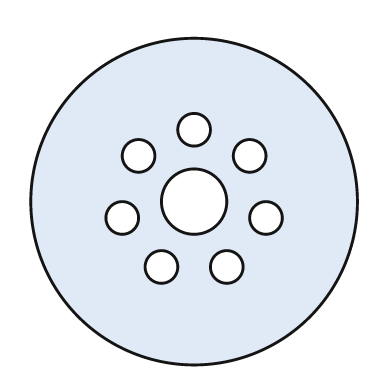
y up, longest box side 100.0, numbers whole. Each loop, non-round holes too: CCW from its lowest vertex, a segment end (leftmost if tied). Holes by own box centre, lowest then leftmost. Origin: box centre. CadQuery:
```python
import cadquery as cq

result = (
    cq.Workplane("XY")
    .moveTo(0.0, 0.0)
    .circle(50.0)
    .moveTo(-10.0, -20.0)
    .circle(5.0)
    .moveTo(10.0, -20.0)
    .circle(5.0)
    .moveTo(-22.0, -5.0)
    .circle(5.0)
    .moveTo(22.0, -5.0)
    .circle(5.0)
    .moveTo(0.0, 0.0)
    .circle(10.0)
    .moveTo(-17.0, 14.0)
    .circle(5.0)
    .moveTo(17.0, 14.0)
    .circle(5.0)
    .moveTo(0.0, 22.0)
    .circle(5.0)
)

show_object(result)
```